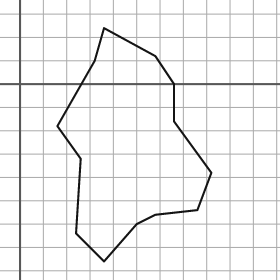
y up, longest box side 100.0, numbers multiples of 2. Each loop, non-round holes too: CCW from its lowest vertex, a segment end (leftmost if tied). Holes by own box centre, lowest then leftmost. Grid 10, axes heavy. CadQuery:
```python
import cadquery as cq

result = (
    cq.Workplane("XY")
    .moveTo(36.0, -76.0)
    .lineTo(50.0, -60.0)
    .lineTo(58.0, -56.0)
    .lineTo(76.0, -54.0)
    .lineTo(82.0, -38.0)
    .lineTo(66.0, -16.0)
    .lineTo(66.0, 0.0)
    .lineTo(58.0, 12.0)
    .lineTo(36.0, 24.0)
    .lineTo(32.0, 10.0)
    .lineTo(16.0, -18.0)
    .lineTo(26.0, -32.0)
    .lineTo(24.0, -64.0)
    .close()
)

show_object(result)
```